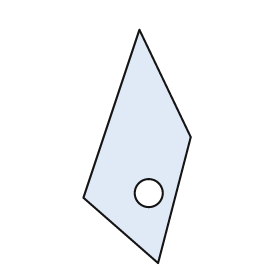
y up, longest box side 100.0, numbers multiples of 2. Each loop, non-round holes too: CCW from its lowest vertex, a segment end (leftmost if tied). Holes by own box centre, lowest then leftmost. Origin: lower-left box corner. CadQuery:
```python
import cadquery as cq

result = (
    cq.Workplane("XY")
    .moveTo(32.0, 0.0)
    .lineTo(46.0, 54.0)
    .lineTo(24.0, 100.0)
    .lineTo(0.0, 28.0)
    .close()
    .moveTo(28.0, 30.0)
    .circle(6.0)
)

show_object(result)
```